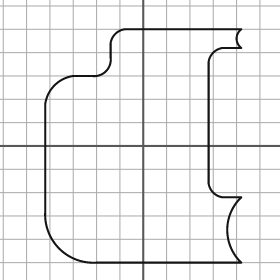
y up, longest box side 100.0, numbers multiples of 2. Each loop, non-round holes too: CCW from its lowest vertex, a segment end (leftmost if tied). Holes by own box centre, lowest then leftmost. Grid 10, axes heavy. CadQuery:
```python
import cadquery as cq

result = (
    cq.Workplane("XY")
    .moveTo(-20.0, -50.0)
    .lineTo(42.0, -50.0)
    .threePointArc((36.0, -36.0), (42.0, -22.0))
    .lineTo(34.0, -22.0)
    .threePointArc((30.0, -20.0), (28.0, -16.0))
    .lineTo(28.0, 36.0)
    .threePointArc((30.0, 40.0), (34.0, 42.0))
    .lineTo(42.0, 42.0)
    .threePointArc((40.0, 46.0), (42.0, 50.0))
    .lineTo(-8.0, 50.0)
    .threePointArc((-12.0, 48.0), (-14.0, 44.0))
    .lineTo(-14.0, 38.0)
    .threePointArc((-16.0, 32.0), (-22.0, 30.0))
    .lineTo(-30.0, 30.0)
    .threePointArc((-38.0, 26.0), (-42.0, 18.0))
    .lineTo(-42.0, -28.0)
    .threePointArc((-36.0, -44.0), (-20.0, -50.0))
    .close()
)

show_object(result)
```